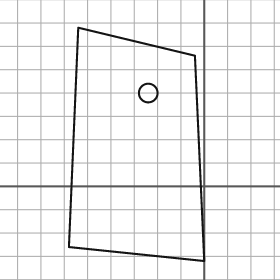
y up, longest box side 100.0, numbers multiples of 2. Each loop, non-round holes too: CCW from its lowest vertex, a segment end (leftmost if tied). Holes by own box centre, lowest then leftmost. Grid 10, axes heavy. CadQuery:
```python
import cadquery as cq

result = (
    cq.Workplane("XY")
    .moveTo(0.0, -32.0)
    .lineTo(-4.0, 56.0)
    .lineTo(-54.0, 68.0)
    .lineTo(-58.0, -26.0)
    .close()
    .moveTo(-24.0, 40.0)
    .circle(4.0)
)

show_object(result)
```